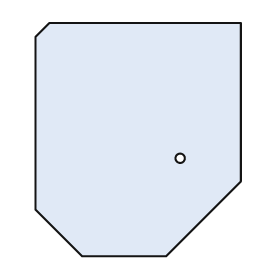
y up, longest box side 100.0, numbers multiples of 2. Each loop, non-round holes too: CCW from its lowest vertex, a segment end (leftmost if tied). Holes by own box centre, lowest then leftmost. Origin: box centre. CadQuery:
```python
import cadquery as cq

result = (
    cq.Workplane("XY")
    .moveTo(-24.0, -50.0)
    .lineTo(12.0, -50.0)
    .lineTo(44.0, -18.0)
    .lineTo(44.0, 50.0)
    .lineTo(-38.0, 50.0)
    .lineTo(-44.0, 44.0)
    .lineTo(-44.0, -30.0)
    .close()
    .moveTo(18.0, -8.0)
    .circle(2.0)
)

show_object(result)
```